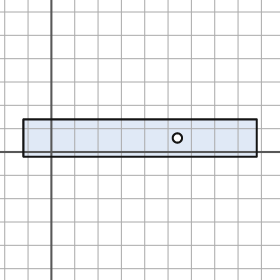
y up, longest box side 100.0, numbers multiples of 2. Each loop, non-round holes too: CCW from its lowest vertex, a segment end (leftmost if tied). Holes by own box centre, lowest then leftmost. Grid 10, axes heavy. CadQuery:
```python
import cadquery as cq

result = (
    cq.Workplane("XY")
    .moveTo(-12.0, -2.0)
    .lineTo(88.0, -2.0)
    .lineTo(88.0, 14.0)
    .lineTo(-12.0, 14.0)
    .close()
    .moveTo(54.0, 6.0)
    .circle(2.0)
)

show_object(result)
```